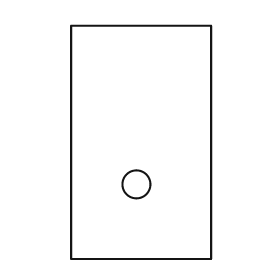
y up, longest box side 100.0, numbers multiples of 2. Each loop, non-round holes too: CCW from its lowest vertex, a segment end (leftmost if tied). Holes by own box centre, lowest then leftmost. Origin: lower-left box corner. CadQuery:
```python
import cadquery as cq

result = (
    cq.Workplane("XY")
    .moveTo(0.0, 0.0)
    .lineTo(60.0, 0.0)
    .lineTo(60.0, 100.0)
    .lineTo(0.0, 100.0)
    .close()
    .moveTo(28.0, 32.0)
    .circle(6.0)
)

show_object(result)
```